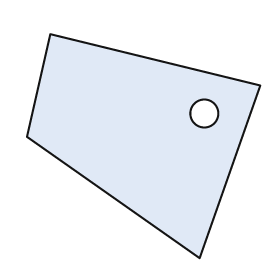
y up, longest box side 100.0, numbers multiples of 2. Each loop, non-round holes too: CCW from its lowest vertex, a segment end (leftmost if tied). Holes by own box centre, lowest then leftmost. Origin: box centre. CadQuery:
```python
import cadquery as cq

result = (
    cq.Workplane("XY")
    .moveTo(24.0, -48.0)
    .lineTo(50.0, 26.0)
    .lineTo(-40.0, 48.0)
    .lineTo(-50.0, 4.0)
    .close()
    .moveTo(26.0, 14.0)
    .circle(6.0)
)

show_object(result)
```